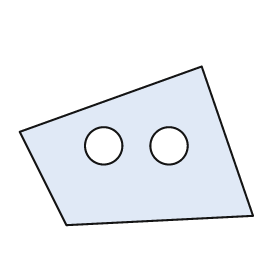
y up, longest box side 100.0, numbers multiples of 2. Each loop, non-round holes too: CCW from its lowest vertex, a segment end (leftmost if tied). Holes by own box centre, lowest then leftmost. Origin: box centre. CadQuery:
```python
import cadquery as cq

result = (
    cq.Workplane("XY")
    .moveTo(-30.0, -34.0)
    .lineTo(50.0, -30.0)
    .lineTo(28.0, 34.0)
    .lineTo(-50.0, 6.0)
    .close()
    .moveTo(-14.0, 0.0)
    .circle(8.0)
    .moveTo(14.0, 0.0)
    .circle(8.0)
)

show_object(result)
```